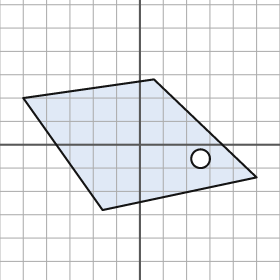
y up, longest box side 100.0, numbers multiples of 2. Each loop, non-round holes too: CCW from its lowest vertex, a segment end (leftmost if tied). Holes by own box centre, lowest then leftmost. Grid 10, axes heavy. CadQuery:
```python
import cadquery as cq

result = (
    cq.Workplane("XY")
    .moveTo(-16.0, -28.0)
    .lineTo(50.0, -14.0)
    .lineTo(6.0, 28.0)
    .lineTo(-50.0, 20.0)
    .close()
    .moveTo(26.0, -6.0)
    .circle(4.0)
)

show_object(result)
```